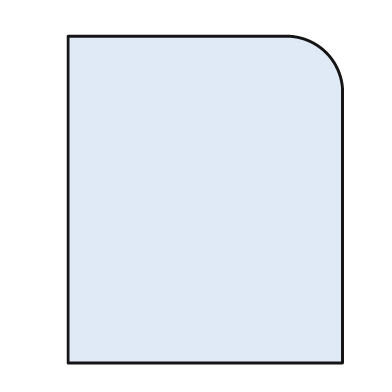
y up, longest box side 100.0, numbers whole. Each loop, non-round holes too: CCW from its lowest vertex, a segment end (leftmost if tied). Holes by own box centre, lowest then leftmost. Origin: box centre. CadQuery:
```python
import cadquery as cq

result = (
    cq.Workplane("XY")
    .moveTo(-42.0, -50.0)
    .lineTo(42.0, -50.0)
    .lineTo(42.0, 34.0)
    .threePointArc((37.0, 45.0), (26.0, 50.0))
    .lineTo(-42.0, 50.0)
    .close()
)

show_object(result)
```